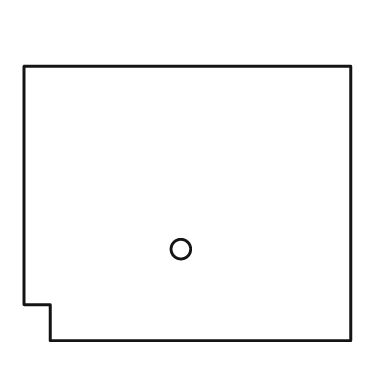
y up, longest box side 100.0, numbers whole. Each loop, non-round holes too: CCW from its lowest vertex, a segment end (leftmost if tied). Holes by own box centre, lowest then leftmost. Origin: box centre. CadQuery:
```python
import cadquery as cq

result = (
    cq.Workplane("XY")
    .moveTo(-42.0, -42.0)
    .lineTo(50.0, -42.0)
    .lineTo(50.0, 42.0)
    .lineTo(-50.0, 42.0)
    .lineTo(-50.0, -31.0)
    .lineTo(-42.0, -31.0)
    .close()
    .moveTo(-2.0, -14.0)
    .circle(3.0)
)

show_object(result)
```